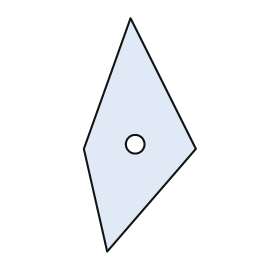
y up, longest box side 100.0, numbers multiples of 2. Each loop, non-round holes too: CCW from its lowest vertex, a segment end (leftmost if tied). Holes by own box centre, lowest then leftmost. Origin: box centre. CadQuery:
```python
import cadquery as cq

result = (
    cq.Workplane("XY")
    .moveTo(-14.0, -50.0)
    .lineTo(24.0, -6.0)
    .lineTo(-4.0, 50.0)
    .lineTo(-24.0, -6.0)
    .close()
    .moveTo(-2.0, -4.0)
    .circle(4.0)
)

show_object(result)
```